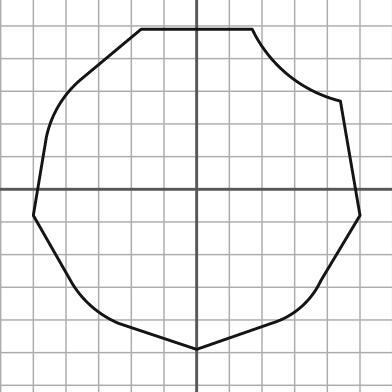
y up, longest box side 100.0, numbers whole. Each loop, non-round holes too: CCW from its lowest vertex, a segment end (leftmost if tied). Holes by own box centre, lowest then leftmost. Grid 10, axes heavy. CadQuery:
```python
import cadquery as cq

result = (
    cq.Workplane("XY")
    .moveTo(0.0, -49.0)
    .lineTo(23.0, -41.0)
    .threePointArc((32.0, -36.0), (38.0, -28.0))
    .lineTo(50.0, -8.0)
    .lineTo(44.0, 27.0)
    .threePointArc((28.0, 35.0), (17.0, 49.0))
    .lineTo(-17.0, 49.0)
    .lineTo(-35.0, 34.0)
    .threePointArc((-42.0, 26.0), (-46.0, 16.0))
    .lineTo(-50.0, -8.0)
    .lineTo(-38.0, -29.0)
    .threePointArc((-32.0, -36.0), (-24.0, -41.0))
    .close()
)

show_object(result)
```